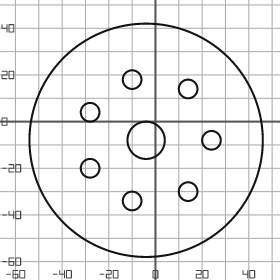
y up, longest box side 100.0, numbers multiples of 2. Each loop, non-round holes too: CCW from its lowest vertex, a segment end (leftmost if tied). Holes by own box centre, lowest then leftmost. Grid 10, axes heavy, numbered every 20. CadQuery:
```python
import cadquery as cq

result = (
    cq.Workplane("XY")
    .moveTo(-4.0, -8.0)
    .circle(50.0)
    .moveTo(-10.0, -34.0)
    .circle(4.0)
    .moveTo(14.0, -30.0)
    .circle(4.0)
    .moveTo(-28.0, -20.0)
    .circle(4.0)
    .moveTo(-4.0, -8.0)
    .circle(8.0)
    .moveTo(24.0, -8.0)
    .circle(4.0)
    .moveTo(-28.0, 4.0)
    .circle(4.0)
    .moveTo(14.0, 14.0)
    .circle(4.0)
    .moveTo(-10.0, 18.0)
    .circle(4.0)
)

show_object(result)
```